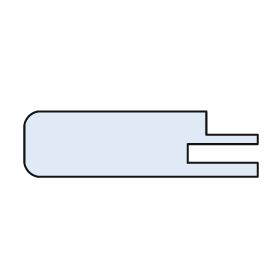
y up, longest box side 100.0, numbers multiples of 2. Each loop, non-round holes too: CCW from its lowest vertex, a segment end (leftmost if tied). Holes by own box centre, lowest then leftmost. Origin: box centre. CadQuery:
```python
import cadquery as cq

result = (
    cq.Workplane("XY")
    .moveTo(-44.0, -14.0)
    .lineTo(50.0, -14.0)
    .lineTo(50.0, -8.0)
    .lineTo(20.0, -8.0)
    .lineTo(20.0, 0.0)
    .lineTo(50.0, 0.0)
    .lineTo(50.0, 4.0)
    .lineTo(28.0, 4.0)
    .lineTo(28.0, 14.0)
    .lineTo(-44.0, 14.0)
    .threePointArc((-48.0, 12.0), (-50.0, 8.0))
    .lineTo(-50.0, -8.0)
    .threePointArc((-48.0, -12.0), (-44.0, -14.0))
    .close()
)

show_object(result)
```